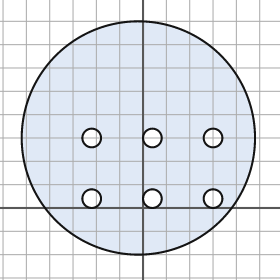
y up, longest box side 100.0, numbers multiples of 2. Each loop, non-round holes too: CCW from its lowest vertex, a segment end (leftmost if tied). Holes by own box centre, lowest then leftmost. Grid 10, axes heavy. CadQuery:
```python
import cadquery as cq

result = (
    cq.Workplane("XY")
    .moveTo(-2.0, 30.0)
    .circle(50.0)
    .moveTo(-22.0, 4.0)
    .circle(4.0)
    .moveTo(4.0, 4.0)
    .circle(4.0)
    .moveTo(30.0, 4.0)
    .circle(4.0)
    .moveTo(-22.0, 30.0)
    .circle(4.0)
    .moveTo(4.0, 30.0)
    .circle(4.0)
    .moveTo(30.0, 30.0)
    .circle(4.0)
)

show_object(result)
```